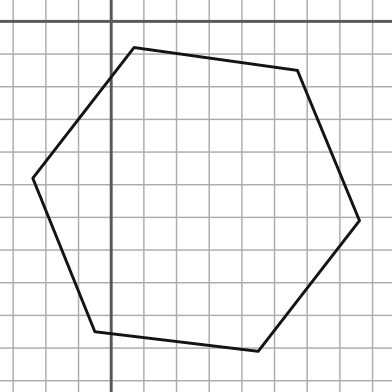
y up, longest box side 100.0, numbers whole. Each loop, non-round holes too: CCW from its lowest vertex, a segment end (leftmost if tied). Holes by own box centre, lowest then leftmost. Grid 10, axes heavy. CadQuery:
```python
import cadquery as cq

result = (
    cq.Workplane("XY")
    .moveTo(45.0, -101.0)
    .lineTo(76.0, -61.0)
    .lineTo(57.0, -15.0)
    .lineTo(7.0, -8.0)
    .lineTo(-24.0, -48.0)
    .lineTo(-5.0, -95.0)
    .close()
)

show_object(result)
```